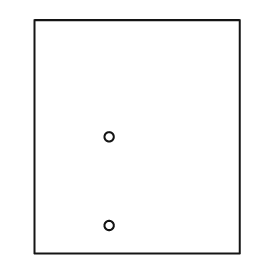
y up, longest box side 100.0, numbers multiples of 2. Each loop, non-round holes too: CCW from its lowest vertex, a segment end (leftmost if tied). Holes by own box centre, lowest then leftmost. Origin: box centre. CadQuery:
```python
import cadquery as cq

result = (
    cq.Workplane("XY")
    .moveTo(-44.0, -50.0)
    .lineTo(44.0, -50.0)
    .lineTo(44.0, 50.0)
    .lineTo(-44.0, 50.0)
    .close()
    .moveTo(-12.0, -38.0)
    .circle(2.0)
    .moveTo(-12.0, 0.0)
    .circle(2.0)
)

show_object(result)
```